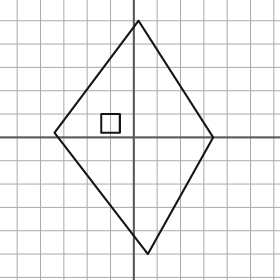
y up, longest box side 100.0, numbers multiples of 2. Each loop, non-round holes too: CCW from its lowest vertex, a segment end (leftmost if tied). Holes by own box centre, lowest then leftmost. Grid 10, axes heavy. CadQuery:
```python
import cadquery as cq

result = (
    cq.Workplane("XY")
    .moveTo(6.0, -50.0)
    .lineTo(34.0, 0.0)
    .lineTo(2.0, 50.0)
    .lineTo(-34.0, 2.0)
    .close()
    .moveTo(-14.0, 2.0)
    .lineTo(-6.0, 2.0)
    .lineTo(-6.0, 10.0)
    .lineTo(-14.0, 10.0)
    .close()
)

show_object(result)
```